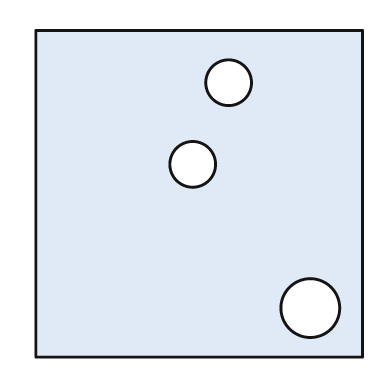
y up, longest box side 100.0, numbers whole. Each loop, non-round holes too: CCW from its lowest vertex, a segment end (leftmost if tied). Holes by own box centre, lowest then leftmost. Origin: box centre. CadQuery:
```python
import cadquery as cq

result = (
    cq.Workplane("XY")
    .moveTo(-50.0, -50.0)
    .lineTo(50.0, -50.0)
    .lineTo(50.0, 50.0)
    .lineTo(-50.0, 50.0)
    .close()
    .moveTo(34.0, -35.0)
    .circle(9.0)
    .moveTo(-2.0, 9.0)
    .circle(7.0)
    .moveTo(9.0, 34.0)
    .circle(7.0)
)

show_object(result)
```